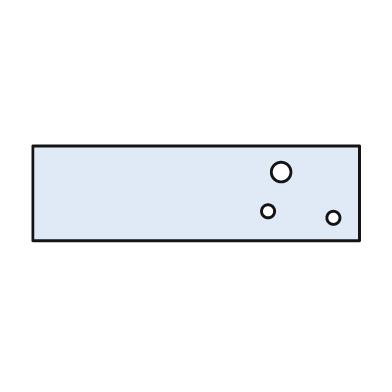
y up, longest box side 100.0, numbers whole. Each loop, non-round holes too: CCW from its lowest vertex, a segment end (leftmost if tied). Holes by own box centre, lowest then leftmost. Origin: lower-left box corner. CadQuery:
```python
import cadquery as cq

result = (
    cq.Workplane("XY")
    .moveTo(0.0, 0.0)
    .lineTo(100.0, 0.0)
    .lineTo(100.0, 29.0)
    .lineTo(0.0, 29.0)
    .close()
    .moveTo(92.0, 7.0)
    .circle(2.0)
    .moveTo(72.0, 9.0)
    .circle(2.0)
    .moveTo(76.0, 21.0)
    .circle(3.0)
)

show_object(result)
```